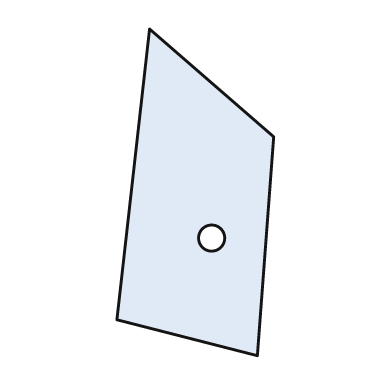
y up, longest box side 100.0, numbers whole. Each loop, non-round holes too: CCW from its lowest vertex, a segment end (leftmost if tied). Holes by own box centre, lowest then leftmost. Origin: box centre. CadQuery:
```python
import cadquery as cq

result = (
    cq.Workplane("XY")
    .moveTo(19.0, -50.0)
    .lineTo(24.0, 17.0)
    .lineTo(-14.0, 50.0)
    .lineTo(-24.0, -39.0)
    .close()
    .moveTo(5.0, -14.0)
    .circle(4.0)
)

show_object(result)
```